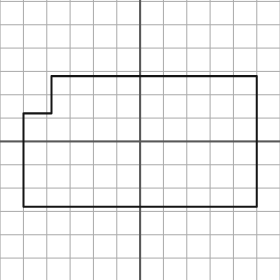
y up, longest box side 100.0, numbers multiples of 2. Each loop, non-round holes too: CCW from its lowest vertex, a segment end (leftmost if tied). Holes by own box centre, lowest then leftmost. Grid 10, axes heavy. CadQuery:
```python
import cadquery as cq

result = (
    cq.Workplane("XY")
    .moveTo(-50.0, -28.0)
    .lineTo(50.0, -28.0)
    .lineTo(50.0, 28.0)
    .lineTo(-38.0, 28.0)
    .lineTo(-38.0, 12.0)
    .lineTo(-50.0, 12.0)
    .close()
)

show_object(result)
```